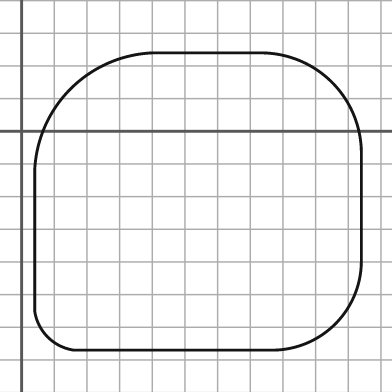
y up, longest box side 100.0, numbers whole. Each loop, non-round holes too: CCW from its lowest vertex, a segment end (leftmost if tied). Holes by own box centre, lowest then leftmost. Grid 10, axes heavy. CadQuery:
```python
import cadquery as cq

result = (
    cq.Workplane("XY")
    .moveTo(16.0, -67.0)
    .lineTo(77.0, -67.0)
    .threePointArc((96.0, -59.0), (104.0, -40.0))
    .lineTo(104.0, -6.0)
    .threePointArc((95.0, 15.0), (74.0, 24.0))
    .lineTo(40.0, 24.0)
    .threePointArc((15.0, 13.0), (4.0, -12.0))
    .lineTo(4.0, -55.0)
    .threePointArc((8.0, -63.0), (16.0, -67.0))
    .close()
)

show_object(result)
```